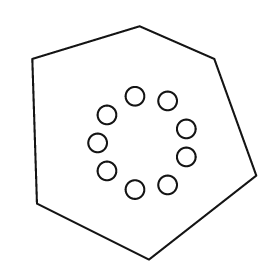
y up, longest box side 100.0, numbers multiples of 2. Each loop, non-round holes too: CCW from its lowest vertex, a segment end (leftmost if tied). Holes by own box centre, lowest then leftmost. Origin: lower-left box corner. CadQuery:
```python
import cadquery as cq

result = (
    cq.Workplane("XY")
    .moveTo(50.0, 0.0)
    .lineTo(96.0, 36.0)
    .lineTo(78.0, 86.0)
    .lineTo(46.0, 100.0)
    .lineTo(0.0, 86.0)
    .lineTo(2.0, 24.0)
    .close()
    .moveTo(44.0, 30.0)
    .circle(4.0)
    .moveTo(58.0, 32.0)
    .circle(4.0)
    .moveTo(32.0, 38.0)
    .circle(4.0)
    .moveTo(66.0, 44.0)
    .circle(4.0)
    .moveTo(28.0, 50.0)
    .circle(4.0)
    .moveTo(66.0, 56.0)
    .circle(4.0)
    .moveTo(32.0, 62.0)
    .circle(4.0)
    .moveTo(58.0, 68.0)
    .circle(4.0)
    .moveTo(44.0, 70.0)
    .circle(4.0)
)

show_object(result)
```